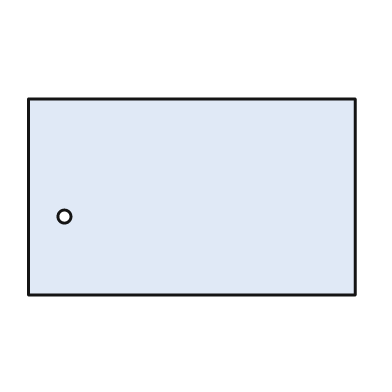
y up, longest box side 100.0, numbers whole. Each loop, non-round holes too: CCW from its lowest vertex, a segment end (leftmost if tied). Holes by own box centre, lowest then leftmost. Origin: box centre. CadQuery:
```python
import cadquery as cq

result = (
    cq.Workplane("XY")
    .moveTo(-50.0, -30.0)
    .lineTo(50.0, -30.0)
    .lineTo(50.0, 30.0)
    .lineTo(-50.0, 30.0)
    .close()
    .moveTo(-39.0, -6.0)
    .circle(2.0)
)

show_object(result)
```